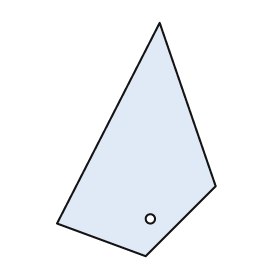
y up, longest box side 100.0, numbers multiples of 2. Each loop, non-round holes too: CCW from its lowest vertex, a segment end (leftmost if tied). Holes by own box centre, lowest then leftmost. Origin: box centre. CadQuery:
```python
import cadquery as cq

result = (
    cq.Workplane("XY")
    .moveTo(4.0, -50.0)
    .lineTo(34.0, -20.0)
    .lineTo(10.0, 50.0)
    .lineTo(-34.0, -36.0)
    .close()
    .moveTo(6.0, -34.0)
    .circle(2.0)
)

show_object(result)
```